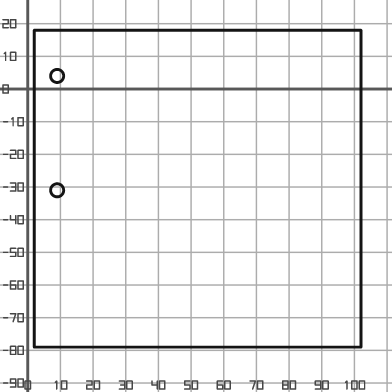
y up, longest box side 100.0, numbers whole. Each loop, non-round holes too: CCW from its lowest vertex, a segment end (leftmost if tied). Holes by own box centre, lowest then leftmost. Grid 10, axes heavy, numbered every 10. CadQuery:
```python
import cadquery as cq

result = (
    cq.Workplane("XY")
    .moveTo(2.0, -79.0)
    .lineTo(102.0, -79.0)
    .lineTo(102.0, 18.0)
    .lineTo(2.0, 18.0)
    .close()
    .moveTo(9.0, -31.0)
    .circle(2.0)
    .moveTo(9.0, 4.0)
    .circle(2.0)
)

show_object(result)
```